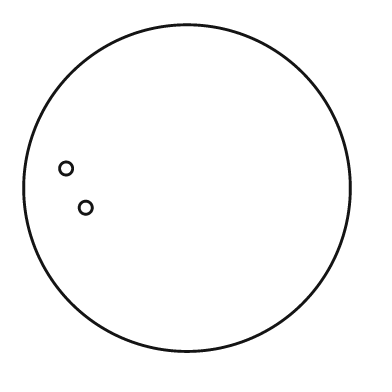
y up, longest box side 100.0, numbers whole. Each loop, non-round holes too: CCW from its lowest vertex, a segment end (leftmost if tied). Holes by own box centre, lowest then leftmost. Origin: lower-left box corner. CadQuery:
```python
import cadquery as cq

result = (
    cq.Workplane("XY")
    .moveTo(50.0, 50.0)
    .circle(50.0)
    .moveTo(19.0, 44.0)
    .circle(2.0)
    .moveTo(13.0, 56.0)
    .circle(2.0)
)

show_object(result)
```